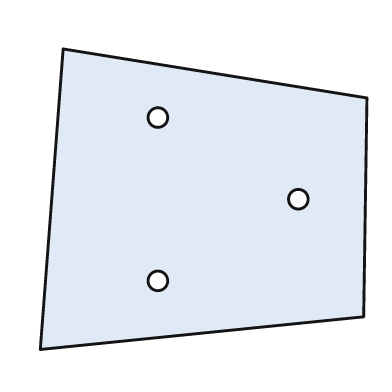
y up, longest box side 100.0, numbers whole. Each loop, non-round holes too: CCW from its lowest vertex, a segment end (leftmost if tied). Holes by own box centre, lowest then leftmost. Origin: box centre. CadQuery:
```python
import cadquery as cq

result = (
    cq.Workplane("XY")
    .moveTo(-50.0, -46.0)
    .lineTo(49.0, -36.0)
    .lineTo(50.0, 31.0)
    .lineTo(-43.0, 46.0)
    .close()
    .moveTo(-14.0, -25.0)
    .circle(3.0)
    .moveTo(29.0, 0.0)
    .circle(3.0)
    .moveTo(-14.0, 25.0)
    .circle(3.0)
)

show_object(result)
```